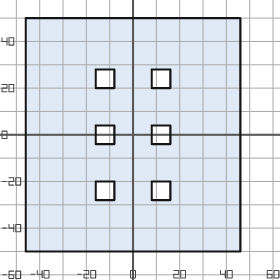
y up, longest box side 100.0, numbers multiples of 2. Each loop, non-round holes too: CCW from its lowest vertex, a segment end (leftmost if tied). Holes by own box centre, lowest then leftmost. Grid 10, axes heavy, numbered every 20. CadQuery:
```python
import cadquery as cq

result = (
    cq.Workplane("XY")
    .moveTo(-46.0, -50.0)
    .lineTo(46.0, -50.0)
    .lineTo(46.0, 50.0)
    .lineTo(-46.0, 50.0)
    .close()
    .moveTo(-16.0, -28.0)
    .lineTo(-8.0, -28.0)
    .lineTo(-8.0, -20.0)
    .lineTo(-16.0, -20.0)
    .close()
    .moveTo(8.0, -28.0)
    .lineTo(16.0, -28.0)
    .lineTo(16.0, -20.0)
    .lineTo(8.0, -20.0)
    .close()
    .moveTo(-16.0, -4.0)
    .lineTo(-8.0, -4.0)
    .lineTo(-8.0, 4.0)
    .lineTo(-16.0, 4.0)
    .close()
    .moveTo(8.0, -4.0)
    .lineTo(16.0, -4.0)
    .lineTo(16.0, 4.0)
    .lineTo(8.0, 4.0)
    .close()
    .moveTo(-16.0, 20.0)
    .lineTo(-8.0, 20.0)
    .lineTo(-8.0, 28.0)
    .lineTo(-16.0, 28.0)
    .close()
    .moveTo(8.0, 20.0)
    .lineTo(16.0, 20.0)
    .lineTo(16.0, 28.0)
    .lineTo(8.0, 28.0)
    .close()
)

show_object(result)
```